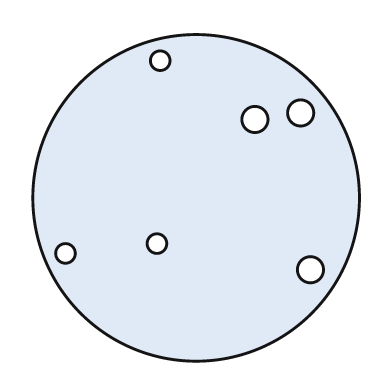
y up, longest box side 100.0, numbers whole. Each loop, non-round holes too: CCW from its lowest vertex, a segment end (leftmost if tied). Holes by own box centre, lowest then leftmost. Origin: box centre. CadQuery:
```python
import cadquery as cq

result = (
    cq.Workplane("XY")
    .moveTo(0.0, 0.0)
    .circle(50.0)
    .moveTo(35.0, -22.0)
    .circle(4.0)
    .moveTo(-40.0, -17.0)
    .circle(3.0)
    .moveTo(-12.0, -14.0)
    .circle(3.0)
    .moveTo(18.0, 24.0)
    .circle(4.0)
    .moveTo(32.0, 26.0)
    .circle(4.0)
    .moveTo(-11.0, 42.0)
    .circle(3.0)
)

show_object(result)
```